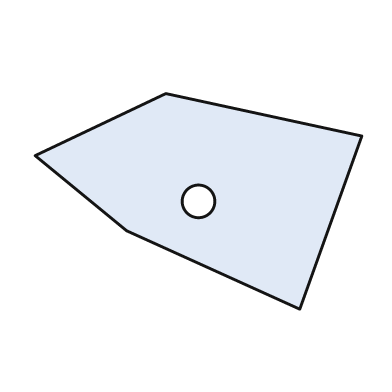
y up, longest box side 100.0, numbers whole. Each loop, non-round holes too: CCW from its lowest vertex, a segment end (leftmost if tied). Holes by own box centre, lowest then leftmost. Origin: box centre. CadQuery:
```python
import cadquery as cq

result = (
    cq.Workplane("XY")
    .moveTo(31.0, -33.0)
    .lineTo(50.0, 20.0)
    .lineTo(-10.0, 33.0)
    .lineTo(-50.0, 14.0)
    .lineTo(-22.0, -9.0)
    .close()
    .moveTo(0.0, 0.0)
    .circle(5.0)
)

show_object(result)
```